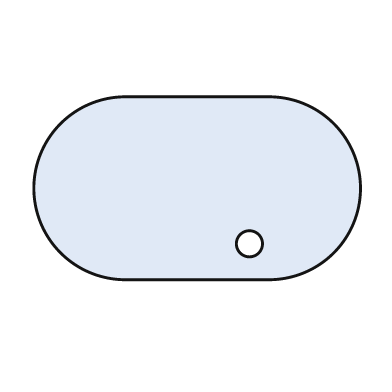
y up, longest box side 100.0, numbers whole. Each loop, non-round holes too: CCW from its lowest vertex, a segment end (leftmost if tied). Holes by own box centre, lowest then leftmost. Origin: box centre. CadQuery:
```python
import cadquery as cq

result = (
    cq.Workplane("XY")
    .moveTo(-22.0, -28.0)
    .lineTo(22.0, -28.0)
    .threePointArc((50.0, 0.0), (22.0, 28.0))
    .lineTo(-22.0, 28.0)
    .threePointArc((-50.0, 0.0), (-22.0, -28.0))
    .close()
    .moveTo(16.0, -17.0)
    .circle(4.0)
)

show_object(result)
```